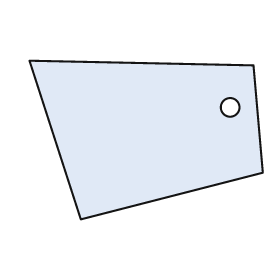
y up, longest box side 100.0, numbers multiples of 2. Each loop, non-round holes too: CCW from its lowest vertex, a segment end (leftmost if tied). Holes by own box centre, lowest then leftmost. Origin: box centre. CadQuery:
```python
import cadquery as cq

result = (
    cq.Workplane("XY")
    .moveTo(-28.0, -34.0)
    .lineTo(50.0, -14.0)
    .lineTo(46.0, 32.0)
    .lineTo(-50.0, 34.0)
    .close()
    .moveTo(36.0, 14.0)
    .circle(4.0)
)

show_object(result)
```